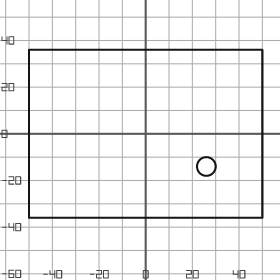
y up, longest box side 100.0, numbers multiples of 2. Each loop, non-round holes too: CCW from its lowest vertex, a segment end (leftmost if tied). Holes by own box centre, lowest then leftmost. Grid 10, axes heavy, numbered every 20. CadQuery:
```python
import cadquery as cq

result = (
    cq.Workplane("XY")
    .moveTo(-50.0, -36.0)
    .lineTo(50.0, -36.0)
    .lineTo(50.0, 36.0)
    .lineTo(-50.0, 36.0)
    .close()
    .moveTo(26.0, -14.0)
    .circle(4.0)
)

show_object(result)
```